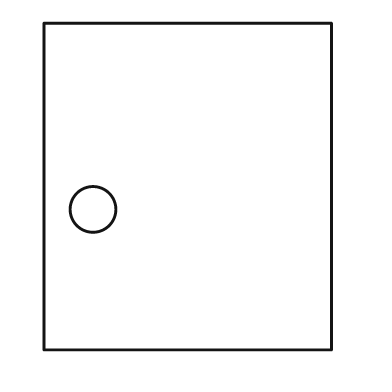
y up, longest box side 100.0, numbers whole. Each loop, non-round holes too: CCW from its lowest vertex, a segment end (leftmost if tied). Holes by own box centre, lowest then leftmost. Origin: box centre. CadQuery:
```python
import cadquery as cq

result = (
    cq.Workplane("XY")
    .moveTo(-44.0, -50.0)
    .lineTo(44.0, -50.0)
    .lineTo(44.0, 50.0)
    .lineTo(-44.0, 50.0)
    .close()
    .moveTo(-29.0, -7.0)
    .circle(7.0)
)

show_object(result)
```